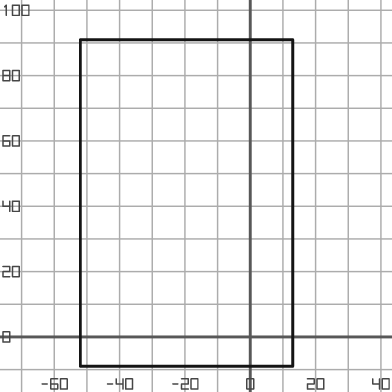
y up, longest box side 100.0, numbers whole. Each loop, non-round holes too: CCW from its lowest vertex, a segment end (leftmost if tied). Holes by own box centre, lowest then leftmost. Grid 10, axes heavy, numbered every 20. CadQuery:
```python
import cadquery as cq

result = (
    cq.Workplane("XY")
    .moveTo(-52.0, -9.0)
    .lineTo(13.0, -9.0)
    .lineTo(13.0, 91.0)
    .lineTo(-52.0, 91.0)
    .close()
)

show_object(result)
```